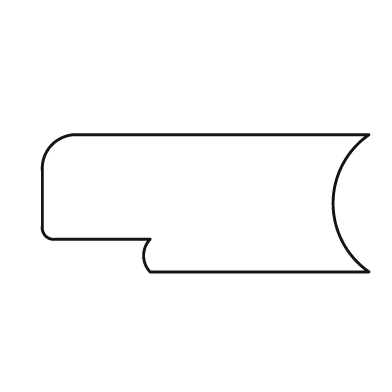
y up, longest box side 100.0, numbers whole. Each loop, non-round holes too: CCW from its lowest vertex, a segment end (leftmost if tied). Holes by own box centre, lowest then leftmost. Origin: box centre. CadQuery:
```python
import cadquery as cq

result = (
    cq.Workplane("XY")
    .moveTo(-17.0, -21.0)
    .lineTo(50.0, -21.0)
    .threePointArc((39.0, 0.0), (50.0, 21.0))
    .lineTo(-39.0, 21.0)
    .threePointArc((-47.0, 18.0), (-50.0, 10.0))
    .lineTo(-50.0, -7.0)
    .threePointArc((-49.0, -10.0), (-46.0, -11.0))
    .lineTo(-17.0, -11.0)
    .threePointArc((-19.0, -16.0), (-17.0, -21.0))
    .close()
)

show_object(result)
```